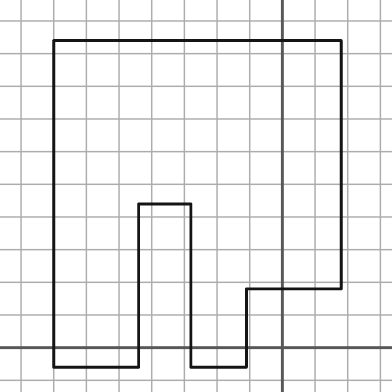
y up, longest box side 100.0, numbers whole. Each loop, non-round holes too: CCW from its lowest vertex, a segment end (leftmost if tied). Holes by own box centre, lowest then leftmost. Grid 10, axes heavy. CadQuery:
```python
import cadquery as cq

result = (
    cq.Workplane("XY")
    .moveTo(-70.0, -6.0)
    .lineTo(-44.0, -6.0)
    .lineTo(-44.0, 44.0)
    .lineTo(-28.0, 44.0)
    .lineTo(-28.0, -6.0)
    .lineTo(-11.0, -6.0)
    .lineTo(-11.0, 18.0)
    .lineTo(18.0, 18.0)
    .lineTo(18.0, 94.0)
    .lineTo(-70.0, 94.0)
    .close()
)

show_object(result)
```